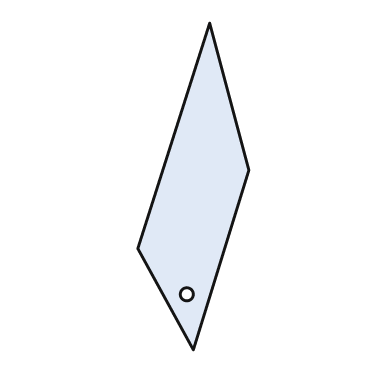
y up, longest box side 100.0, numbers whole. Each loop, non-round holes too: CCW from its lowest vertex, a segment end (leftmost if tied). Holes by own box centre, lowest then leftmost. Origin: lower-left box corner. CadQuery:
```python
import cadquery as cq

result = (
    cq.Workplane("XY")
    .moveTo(17.0, 0.0)
    .lineTo(34.0, 55.0)
    .lineTo(22.0, 100.0)
    .lineTo(0.0, 31.0)
    .close()
    .moveTo(15.0, 17.0)
    .circle(2.0)
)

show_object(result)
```